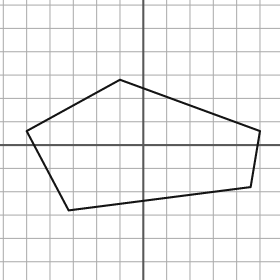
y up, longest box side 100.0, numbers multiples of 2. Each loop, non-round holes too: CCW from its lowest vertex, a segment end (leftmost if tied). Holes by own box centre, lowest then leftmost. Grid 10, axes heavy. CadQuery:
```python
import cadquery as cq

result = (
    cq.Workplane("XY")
    .moveTo(-32.0, -28.0)
    .lineTo(46.0, -18.0)
    .lineTo(50.0, 6.0)
    .lineTo(-10.0, 28.0)
    .lineTo(-50.0, 6.0)
    .close()
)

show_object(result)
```